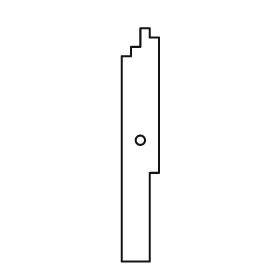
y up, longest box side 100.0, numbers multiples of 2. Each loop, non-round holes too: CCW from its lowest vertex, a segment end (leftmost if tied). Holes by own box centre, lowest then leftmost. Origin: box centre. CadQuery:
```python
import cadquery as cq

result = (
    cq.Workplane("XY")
    .moveTo(-8.0, -50.0)
    .lineTo(4.0, -50.0)
    .lineTo(4.0, -12.0)
    .lineTo(8.0, -12.0)
    .lineTo(8.0, 46.0)
    .lineTo(4.0, 46.0)
    .lineTo(4.0, 50.0)
    .lineTo(0.0, 50.0)
    .lineTo(0.0, 42.0)
    .lineTo(-4.0, 42.0)
    .lineTo(-4.0, 38.0)
    .lineTo(-8.0, 38.0)
    .close()
    .moveTo(0.0, 2.0)
    .circle(2.0)
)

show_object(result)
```